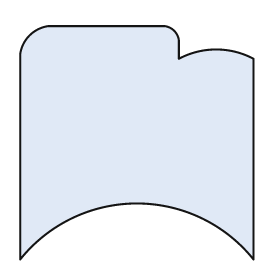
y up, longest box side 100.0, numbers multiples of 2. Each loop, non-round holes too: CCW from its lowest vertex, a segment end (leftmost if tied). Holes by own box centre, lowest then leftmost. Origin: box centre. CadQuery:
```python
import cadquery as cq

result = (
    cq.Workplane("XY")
    .moveTo(-50.0, -50.0)
    .threePointArc((0.0, -26.0), (50.0, -50.0))
    .lineTo(50.0, 36.0)
    .threePointArc((34.0, 40.0), (18.0, 36.0))
    .lineTo(18.0, 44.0)
    .threePointArc((16.0, 48.0), (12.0, 50.0))
    .lineTo(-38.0, 50.0)
    .threePointArc((-46.0, 46.0), (-50.0, 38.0))
    .close()
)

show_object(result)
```